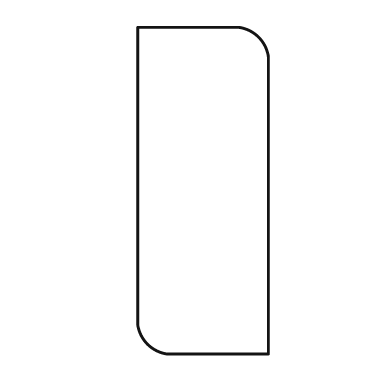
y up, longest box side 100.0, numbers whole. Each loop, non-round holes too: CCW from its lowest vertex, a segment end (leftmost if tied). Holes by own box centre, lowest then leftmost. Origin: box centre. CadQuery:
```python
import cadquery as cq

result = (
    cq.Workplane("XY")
    .moveTo(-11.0, -50.0)
    .lineTo(20.0, -50.0)
    .lineTo(20.0, 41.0)
    .threePointArc((17.0, 47.0), (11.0, 50.0))
    .lineTo(-20.0, 50.0)
    .lineTo(-20.0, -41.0)
    .threePointArc((-17.0, -47.0), (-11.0, -50.0))
    .close()
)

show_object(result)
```